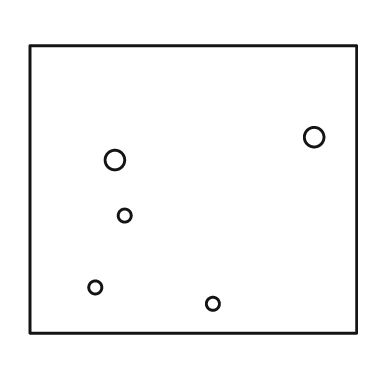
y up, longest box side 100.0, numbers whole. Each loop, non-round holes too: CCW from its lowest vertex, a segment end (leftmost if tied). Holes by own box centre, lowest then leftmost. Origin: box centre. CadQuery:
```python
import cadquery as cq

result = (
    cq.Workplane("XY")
    .moveTo(-50.0, -44.0)
    .lineTo(50.0, -44.0)
    .lineTo(50.0, 44.0)
    .lineTo(-50.0, 44.0)
    .close()
    .moveTo(6.0, -35.0)
    .circle(2.0)
    .moveTo(-30.0, -30.0)
    .circle(2.0)
    .moveTo(-21.0, -8.0)
    .circle(2.0)
    .moveTo(-24.0, 9.0)
    .circle(3.0)
    .moveTo(37.0, 16.0)
    .circle(3.0)
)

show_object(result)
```